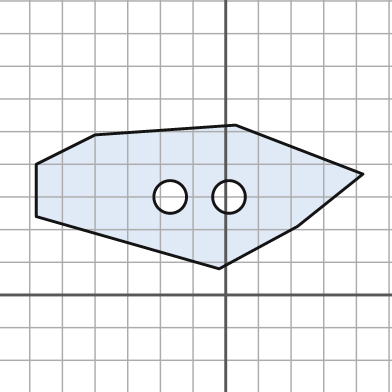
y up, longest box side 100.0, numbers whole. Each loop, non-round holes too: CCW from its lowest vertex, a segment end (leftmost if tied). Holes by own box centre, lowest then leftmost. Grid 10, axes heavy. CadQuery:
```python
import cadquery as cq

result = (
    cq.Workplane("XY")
    .moveTo(-2.0, 8.0)
    .lineTo(22.0, 21.0)
    .lineTo(42.0, 37.0)
    .lineTo(3.0, 52.0)
    .lineTo(-40.0, 49.0)
    .lineTo(-58.0, 40.0)
    .lineTo(-58.0, 24.0)
    .close()
    .moveTo(-17.0, 30.0)
    .circle(5.0)
    .moveTo(1.0, 30.0)
    .circle(5.0)
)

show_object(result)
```